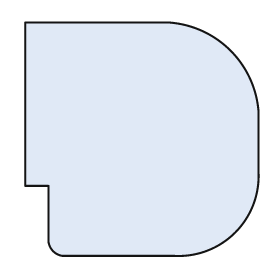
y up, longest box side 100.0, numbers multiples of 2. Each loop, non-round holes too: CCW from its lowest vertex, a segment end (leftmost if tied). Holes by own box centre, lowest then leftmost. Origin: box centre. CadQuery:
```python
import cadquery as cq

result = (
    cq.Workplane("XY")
    .moveTo(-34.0, -50.0)
    .lineTo(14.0, -50.0)
    .threePointArc((40.0, -40.0), (50.0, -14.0))
    .lineTo(50.0, 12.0)
    .threePointArc((38.0, 38.0), (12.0, 50.0))
    .lineTo(-50.0, 50.0)
    .lineTo(-50.0, -20.0)
    .lineTo(-40.0, -20.0)
    .lineTo(-40.0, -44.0)
    .threePointArc((-38.0, -48.0), (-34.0, -50.0))
    .close()
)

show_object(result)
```